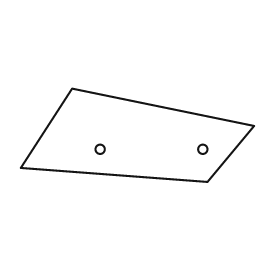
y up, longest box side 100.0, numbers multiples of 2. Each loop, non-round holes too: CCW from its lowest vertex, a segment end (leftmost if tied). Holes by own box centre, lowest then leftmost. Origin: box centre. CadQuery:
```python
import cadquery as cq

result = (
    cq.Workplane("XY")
    .moveTo(30.0, -20.0)
    .lineTo(50.0, 4.0)
    .lineTo(-28.0, 20.0)
    .lineTo(-50.0, -14.0)
    .close()
    .moveTo(-16.0, -6.0)
    .circle(2.0)
    .moveTo(28.0, -6.0)
    .circle(2.0)
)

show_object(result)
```